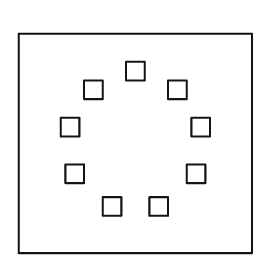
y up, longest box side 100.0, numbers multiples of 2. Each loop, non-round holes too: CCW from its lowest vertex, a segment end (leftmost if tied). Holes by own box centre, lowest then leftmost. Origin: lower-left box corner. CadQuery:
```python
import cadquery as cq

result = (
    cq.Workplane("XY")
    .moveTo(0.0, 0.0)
    .lineTo(100.0, 0.0)
    .lineTo(100.0, 94.0)
    .lineTo(0.0, 94.0)
    .close()
    .moveTo(36.0, 16.0)
    .lineTo(44.0, 16.0)
    .lineTo(44.0, 24.0)
    .lineTo(36.0, 24.0)
    .close()
    .moveTo(56.0, 16.0)
    .lineTo(64.0, 16.0)
    .lineTo(64.0, 24.0)
    .lineTo(56.0, 24.0)
    .close()
    .moveTo(20.0, 30.0)
    .lineTo(28.0, 30.0)
    .lineTo(28.0, 38.0)
    .lineTo(20.0, 38.0)
    .close()
    .moveTo(72.0, 30.0)
    .lineTo(80.0, 30.0)
    .lineTo(80.0, 38.0)
    .lineTo(72.0, 38.0)
    .close()
    .moveTo(18.0, 50.0)
    .lineTo(26.0, 50.0)
    .lineTo(26.0, 58.0)
    .lineTo(18.0, 58.0)
    .close()
    .moveTo(74.0, 50.0)
    .lineTo(82.0, 50.0)
    .lineTo(82.0, 58.0)
    .lineTo(74.0, 58.0)
    .close()
    .moveTo(28.0, 66.0)
    .lineTo(36.0, 66.0)
    .lineTo(36.0, 74.0)
    .lineTo(28.0, 74.0)
    .close()
    .moveTo(64.0, 66.0)
    .lineTo(72.0, 66.0)
    .lineTo(72.0, 74.0)
    .lineTo(64.0, 74.0)
    .close()
    .moveTo(46.0, 74.0)
    .lineTo(54.0, 74.0)
    .lineTo(54.0, 82.0)
    .lineTo(46.0, 82.0)
    .close()
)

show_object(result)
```